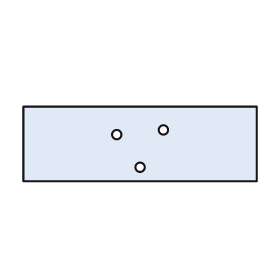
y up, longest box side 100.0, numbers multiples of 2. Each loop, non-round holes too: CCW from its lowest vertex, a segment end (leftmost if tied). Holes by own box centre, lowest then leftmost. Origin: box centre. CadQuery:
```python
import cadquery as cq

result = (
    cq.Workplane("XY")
    .moveTo(-50.0, -16.0)
    .lineTo(50.0, -16.0)
    .lineTo(50.0, 16.0)
    .lineTo(-50.0, 16.0)
    .close()
    .moveTo(0.0, -10.0)
    .circle(2.0)
    .moveTo(-10.0, 4.0)
    .circle(2.0)
    .moveTo(10.0, 6.0)
    .circle(2.0)
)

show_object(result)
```